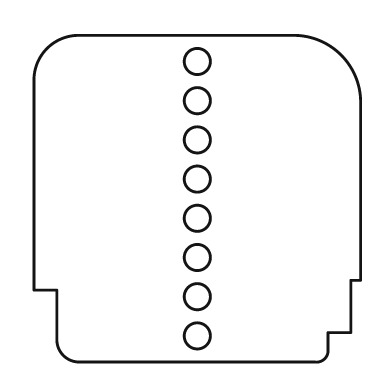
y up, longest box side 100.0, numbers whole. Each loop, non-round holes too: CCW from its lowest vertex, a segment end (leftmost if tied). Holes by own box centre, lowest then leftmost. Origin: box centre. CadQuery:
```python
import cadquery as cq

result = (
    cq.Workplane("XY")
    .moveTo(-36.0, -50.0)
    .lineTo(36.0, -50.0)
    .threePointArc((39.0, -49.0), (40.0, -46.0))
    .lineTo(40.0, -41.0)
    .lineTo(47.0, -41.0)
    .lineTo(47.0, -25.0)
    .lineTo(50.0, -25.0)
    .lineTo(50.0, 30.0)
    .threePointArc((44.0, 44.0), (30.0, 50.0))
    .lineTo(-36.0, 50.0)
    .threePointArc((-46.0, 46.0), (-50.0, 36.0))
    .lineTo(-50.0, -28.0)
    .lineTo(-43.0, -28.0)
    .lineTo(-43.0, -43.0)
    .threePointArc((-41.0, -48.0), (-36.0, -50.0))
    .close()
    .moveTo(0.0, -42.0)
    .circle(4.0)
    .moveTo(0.0, -30.0)
    .circle(4.0)
    .moveTo(0.0, -18.0)
    .circle(4.0)
    .moveTo(0.0, -6.0)
    .circle(4.0)
    .moveTo(0.0, 6.0)
    .circle(4.0)
    .moveTo(0.0, 18.0)
    .circle(4.0)
    .moveTo(0.0, 30.0)
    .circle(4.0)
    .moveTo(0.0, 42.0)
    .circle(4.0)
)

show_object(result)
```